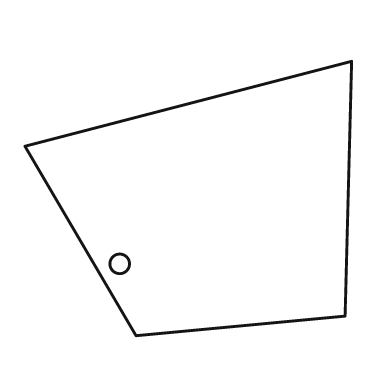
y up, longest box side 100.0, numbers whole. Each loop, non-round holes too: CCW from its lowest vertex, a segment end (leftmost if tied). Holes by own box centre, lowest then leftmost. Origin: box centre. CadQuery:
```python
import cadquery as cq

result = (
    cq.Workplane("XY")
    .moveTo(-16.0, -42.0)
    .lineTo(48.0, -36.0)
    .lineTo(50.0, 42.0)
    .lineTo(-50.0, 16.0)
    .close()
    .moveTo(-21.0, -20.0)
    .circle(3.0)
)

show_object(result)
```